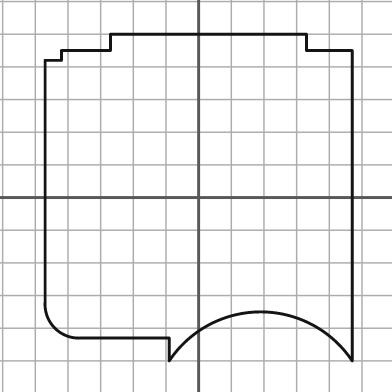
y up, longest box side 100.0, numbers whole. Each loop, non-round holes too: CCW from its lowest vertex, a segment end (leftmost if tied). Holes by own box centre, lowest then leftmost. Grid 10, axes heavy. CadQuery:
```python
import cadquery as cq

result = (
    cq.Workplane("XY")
    .moveTo(-9.0, -50.0)
    .threePointArc((19.0, -35.0), (47.0, -50.0))
    .lineTo(47.0, 45.0)
    .lineTo(33.0, 45.0)
    .lineTo(33.0, 50.0)
    .lineTo(-27.0, 50.0)
    .lineTo(-27.0, 45.0)
    .lineTo(-42.0, 45.0)
    .lineTo(-42.0, 42.0)
    .lineTo(-47.0, 42.0)
    .lineTo(-47.0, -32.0)
    .threePointArc((-44.0, -40.0), (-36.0, -43.0))
    .lineTo(-9.0, -43.0)
    .close()
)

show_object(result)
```